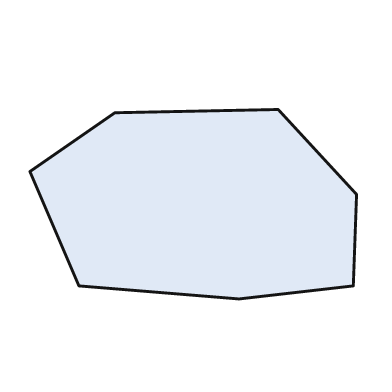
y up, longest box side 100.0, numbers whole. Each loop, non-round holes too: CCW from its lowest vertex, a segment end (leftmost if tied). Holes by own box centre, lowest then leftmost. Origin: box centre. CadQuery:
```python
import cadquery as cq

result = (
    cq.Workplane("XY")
    .moveTo(14.0, -29.0)
    .lineTo(49.0, -25.0)
    .lineTo(50.0, 3.0)
    .lineTo(26.0, 29.0)
    .lineTo(-24.0, 28.0)
    .lineTo(-50.0, 10.0)
    .lineTo(-35.0, -25.0)
    .close()
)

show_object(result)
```